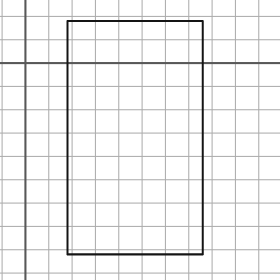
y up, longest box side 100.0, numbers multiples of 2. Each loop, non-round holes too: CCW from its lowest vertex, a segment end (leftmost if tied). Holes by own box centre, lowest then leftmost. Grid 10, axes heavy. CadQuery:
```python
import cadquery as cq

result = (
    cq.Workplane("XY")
    .moveTo(18.0, -82.0)
    .lineTo(76.0, -82.0)
    .lineTo(76.0, 18.0)
    .lineTo(18.0, 18.0)
    .close()
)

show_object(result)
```